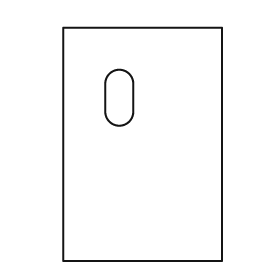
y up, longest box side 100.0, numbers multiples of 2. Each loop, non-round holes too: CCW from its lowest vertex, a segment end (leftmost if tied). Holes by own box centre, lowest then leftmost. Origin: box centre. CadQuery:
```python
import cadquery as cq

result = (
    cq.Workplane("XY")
    .moveTo(-34.0, -50.0)
    .lineTo(34.0, -50.0)
    .lineTo(34.0, 50.0)
    .lineTo(-34.0, 50.0)
    .close()
    .moveTo(-16.0, 14.0)
    .threePointArc((-10.0, 8.0), (-4.0, 14.0))
    .lineTo(-4.0, 26.0)
    .threePointArc((-10.0, 32.0), (-16.0, 26.0))
    .close()
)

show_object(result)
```